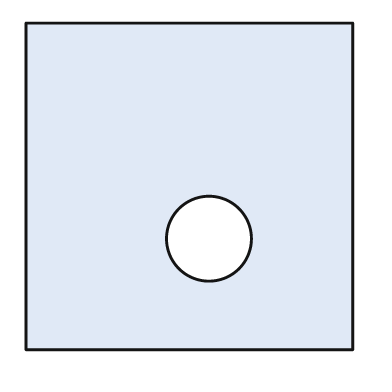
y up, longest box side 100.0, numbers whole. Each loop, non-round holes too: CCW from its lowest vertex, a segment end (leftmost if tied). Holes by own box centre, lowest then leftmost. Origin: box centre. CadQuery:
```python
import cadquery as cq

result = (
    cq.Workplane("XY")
    .moveTo(-50.0, -50.0)
    .lineTo(50.0, -50.0)
    .lineTo(50.0, 50.0)
    .lineTo(-50.0, 50.0)
    .close()
    .moveTo(6.0, -16.0)
    .circle(13.0)
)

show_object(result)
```